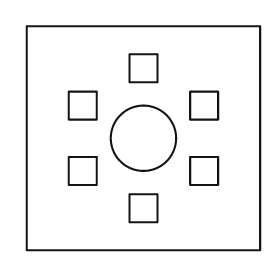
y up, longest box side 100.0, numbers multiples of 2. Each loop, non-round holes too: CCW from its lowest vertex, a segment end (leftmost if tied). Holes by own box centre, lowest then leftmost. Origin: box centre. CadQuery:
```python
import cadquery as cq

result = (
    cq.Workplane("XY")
    .moveTo(-50.0, -48.0)
    .lineTo(50.0, -48.0)
    .lineTo(50.0, 48.0)
    .lineTo(-50.0, 48.0)
    .close()
    .moveTo(-6.0, -36.0)
    .lineTo(6.0, -36.0)
    .lineTo(6.0, -24.0)
    .lineTo(-6.0, -24.0)
    .close()
    .moveTo(-32.0, -20.0)
    .lineTo(-20.0, -20.0)
    .lineTo(-20.0, -8.0)
    .lineTo(-32.0, -8.0)
    .close()
    .moveTo(20.0, -20.0)
    .lineTo(32.0, -20.0)
    .lineTo(32.0, -8.0)
    .lineTo(20.0, -8.0)
    .close()
    .moveTo(0.0, 0.0)
    .circle(14.0)
    .moveTo(-32.0, 8.0)
    .lineTo(-20.0, 8.0)
    .lineTo(-20.0, 20.0)
    .lineTo(-32.0, 20.0)
    .close()
    .moveTo(20.0, 8.0)
    .lineTo(32.0, 8.0)
    .lineTo(32.0, 20.0)
    .lineTo(20.0, 20.0)
    .close()
    .moveTo(-6.0, 24.0)
    .lineTo(6.0, 24.0)
    .lineTo(6.0, 36.0)
    .lineTo(-6.0, 36.0)
    .close()
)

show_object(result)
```